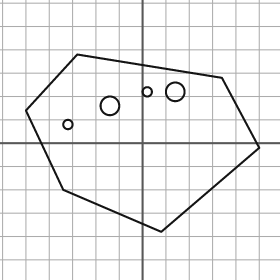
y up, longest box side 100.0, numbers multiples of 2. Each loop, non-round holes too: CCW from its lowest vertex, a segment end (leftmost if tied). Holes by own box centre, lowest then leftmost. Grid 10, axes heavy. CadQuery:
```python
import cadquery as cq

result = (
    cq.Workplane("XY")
    .moveTo(8.0, -38.0)
    .lineTo(50.0, -2.0)
    .lineTo(34.0, 28.0)
    .lineTo(-28.0, 38.0)
    .lineTo(-50.0, 14.0)
    .lineTo(-34.0, -20.0)
    .close()
    .moveTo(-32.0, 8.0)
    .circle(2.0)
    .moveTo(-14.0, 16.0)
    .circle(4.0)
    .moveTo(2.0, 22.0)
    .circle(2.0)
    .moveTo(14.0, 22.0)
    .circle(4.0)
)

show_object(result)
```